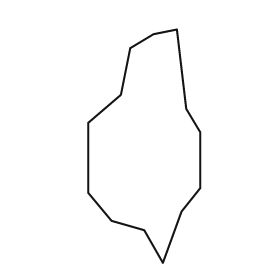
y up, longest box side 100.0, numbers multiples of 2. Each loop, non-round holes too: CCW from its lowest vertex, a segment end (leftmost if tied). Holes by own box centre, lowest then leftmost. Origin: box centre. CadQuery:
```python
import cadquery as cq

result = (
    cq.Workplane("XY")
    .moveTo(8.0, -50.0)
    .lineTo(16.0, -28.0)
    .lineTo(24.0, -18.0)
    .lineTo(24.0, 6.0)
    .lineTo(18.0, 16.0)
    .lineTo(14.0, 50.0)
    .lineTo(4.0, 48.0)
    .lineTo(-6.0, 42.0)
    .lineTo(-10.0, 22.0)
    .lineTo(-24.0, 10.0)
    .lineTo(-24.0, -20.0)
    .lineTo(-14.0, -32.0)
    .lineTo(0.0, -36.0)
    .close()
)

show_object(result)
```